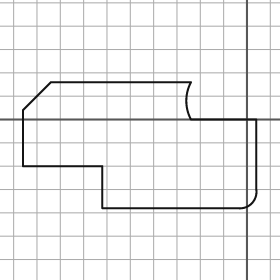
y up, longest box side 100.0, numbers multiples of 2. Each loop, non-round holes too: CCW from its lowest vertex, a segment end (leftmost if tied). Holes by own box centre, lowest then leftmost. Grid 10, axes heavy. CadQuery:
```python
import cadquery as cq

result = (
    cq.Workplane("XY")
    .moveTo(-62.0, -38.0)
    .lineTo(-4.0, -38.0)
    .threePointArc((2.0, -36.0), (4.0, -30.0))
    .lineTo(4.0, 0.0)
    .lineTo(-24.0, 0.0)
    .threePointArc((-26.0, 8.0), (-24.0, 16.0))
    .lineTo(-84.0, 16.0)
    .lineTo(-96.0, 4.0)
    .lineTo(-96.0, -20.0)
    .lineTo(-62.0, -20.0)
    .close()
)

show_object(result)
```